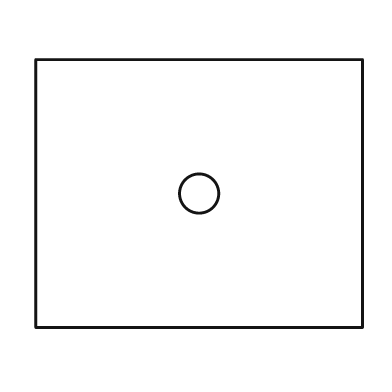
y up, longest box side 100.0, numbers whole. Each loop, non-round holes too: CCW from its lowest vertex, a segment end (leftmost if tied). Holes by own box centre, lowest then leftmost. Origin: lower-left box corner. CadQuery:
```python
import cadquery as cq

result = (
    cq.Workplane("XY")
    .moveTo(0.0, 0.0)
    .lineTo(100.0, 0.0)
    .lineTo(100.0, 82.0)
    .lineTo(0.0, 82.0)
    .close()
    .moveTo(50.0, 41.0)
    .circle(6.0)
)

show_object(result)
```